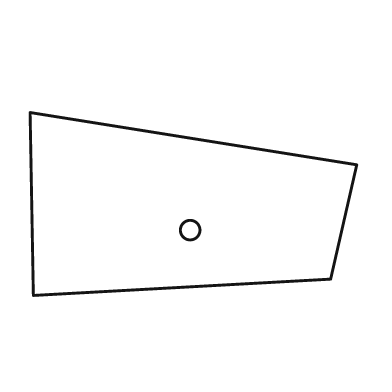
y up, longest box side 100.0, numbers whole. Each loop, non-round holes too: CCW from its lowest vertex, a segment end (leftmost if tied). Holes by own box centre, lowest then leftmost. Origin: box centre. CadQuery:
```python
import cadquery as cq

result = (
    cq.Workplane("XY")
    .moveTo(-49.0, -28.0)
    .lineTo(42.0, -23.0)
    .lineTo(50.0, 12.0)
    .lineTo(-50.0, 28.0)
    .close()
    .moveTo(-1.0, -8.0)
    .circle(3.0)
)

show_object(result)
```